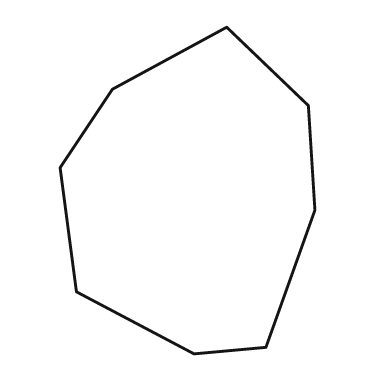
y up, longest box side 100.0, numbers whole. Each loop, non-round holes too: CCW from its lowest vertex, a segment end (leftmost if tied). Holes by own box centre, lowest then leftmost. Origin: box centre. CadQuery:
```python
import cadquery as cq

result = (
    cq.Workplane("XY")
    .moveTo(2.0, -50.0)
    .lineTo(24.0, -48.0)
    .lineTo(39.0, -6.0)
    .lineTo(37.0, 26.0)
    .lineTo(12.0, 50.0)
    .lineTo(-23.0, 31.0)
    .lineTo(-39.0, 7.0)
    .lineTo(-34.0, -31.0)
    .close()
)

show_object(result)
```